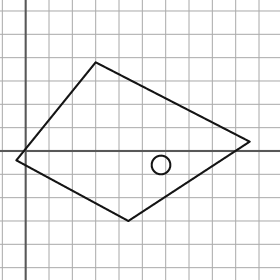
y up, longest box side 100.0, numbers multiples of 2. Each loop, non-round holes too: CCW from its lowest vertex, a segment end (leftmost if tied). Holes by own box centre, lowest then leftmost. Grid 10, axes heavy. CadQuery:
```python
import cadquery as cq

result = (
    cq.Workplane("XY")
    .moveTo(44.0, -30.0)
    .lineTo(96.0, 4.0)
    .lineTo(30.0, 38.0)
    .lineTo(-4.0, -4.0)
    .close()
    .moveTo(58.0, -6.0)
    .circle(4.0)
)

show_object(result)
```